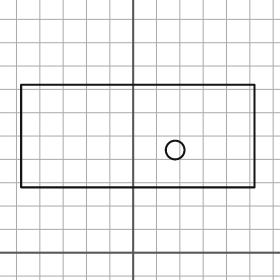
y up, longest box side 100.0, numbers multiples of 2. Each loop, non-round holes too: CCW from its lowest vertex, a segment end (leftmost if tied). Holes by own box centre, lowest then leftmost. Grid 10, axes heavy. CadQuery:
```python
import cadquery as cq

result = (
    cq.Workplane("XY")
    .moveTo(-48.0, 28.0)
    .lineTo(52.0, 28.0)
    .lineTo(52.0, 72.0)
    .lineTo(-48.0, 72.0)
    .close()
    .moveTo(18.0, 44.0)
    .circle(4.0)
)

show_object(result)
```